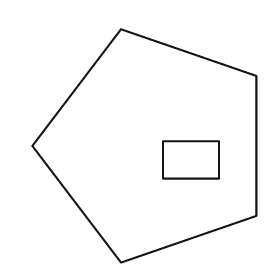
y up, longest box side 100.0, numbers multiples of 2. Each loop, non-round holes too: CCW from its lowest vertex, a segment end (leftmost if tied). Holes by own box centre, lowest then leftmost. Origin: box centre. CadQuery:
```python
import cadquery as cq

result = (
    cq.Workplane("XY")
    .moveTo(-10.0, -50.0)
    .lineTo(48.0, -30.0)
    .lineTo(48.0, 30.0)
    .lineTo(-10.0, 50.0)
    .lineTo(-48.0, 0.0)
    .close()
    .moveTo(8.0, -14.0)
    .lineTo(32.0, -14.0)
    .lineTo(32.0, 2.0)
    .lineTo(8.0, 2.0)
    .close()
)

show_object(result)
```